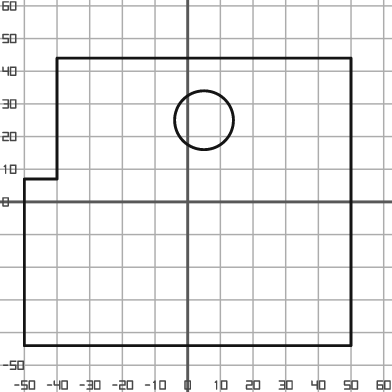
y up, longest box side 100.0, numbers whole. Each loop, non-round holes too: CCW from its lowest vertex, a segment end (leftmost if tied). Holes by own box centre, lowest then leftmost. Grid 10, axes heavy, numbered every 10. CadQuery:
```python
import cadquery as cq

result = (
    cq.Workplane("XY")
    .moveTo(-50.0, -44.0)
    .lineTo(50.0, -44.0)
    .lineTo(50.0, 44.0)
    .lineTo(-40.0, 44.0)
    .lineTo(-40.0, 7.0)
    .lineTo(-50.0, 7.0)
    .close()
    .moveTo(5.0, 25.0)
    .circle(9.0)
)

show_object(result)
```